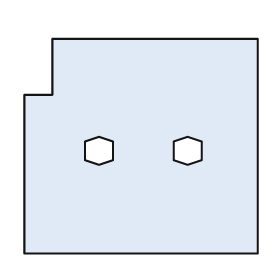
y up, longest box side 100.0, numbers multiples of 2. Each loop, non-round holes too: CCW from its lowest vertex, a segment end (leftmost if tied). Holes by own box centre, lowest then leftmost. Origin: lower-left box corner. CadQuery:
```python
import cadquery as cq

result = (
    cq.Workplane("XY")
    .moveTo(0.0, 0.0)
    .lineTo(100.0, 0.0)
    .lineTo(100.0, 92.0)
    .lineTo(12.0, 92.0)
    .lineTo(12.0, 68.0)
    .lineTo(0.0, 68.0)
    .close()
    .moveTo(32.0, 38.0)
    .lineTo(38.0, 40.0)
    .lineTo(38.0, 48.0)
    .lineTo(32.0, 50.0)
    .lineTo(26.0, 48.0)
    .lineTo(26.0, 40.0)
    .close()
    .moveTo(70.0, 38.0)
    .lineTo(76.0, 40.0)
    .lineTo(76.0, 48.0)
    .lineTo(70.0, 50.0)
    .lineTo(64.0, 48.0)
    .lineTo(64.0, 40.0)
    .close()
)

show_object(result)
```